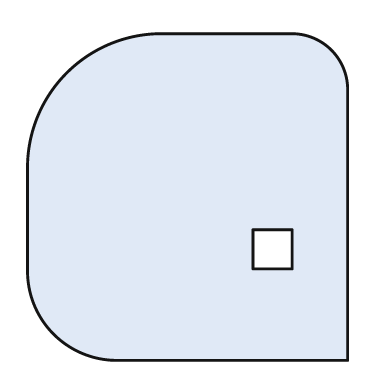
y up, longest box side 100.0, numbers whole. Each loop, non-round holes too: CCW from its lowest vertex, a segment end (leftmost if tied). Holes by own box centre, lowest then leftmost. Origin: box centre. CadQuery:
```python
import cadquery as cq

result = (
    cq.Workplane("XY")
    .moveTo(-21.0, -50.0)
    .lineTo(49.0, -50.0)
    .lineTo(49.0, 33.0)
    .threePointArc((44.0, 45.0), (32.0, 50.0))
    .lineTo(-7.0, 50.0)
    .threePointArc((-37.0, 38.0), (-49.0, 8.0))
    .lineTo(-49.0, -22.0)
    .threePointArc((-41.0, -42.0), (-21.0, -50.0))
    .close()
    .moveTo(20.0, -22.0)
    .lineTo(32.0, -22.0)
    .lineTo(32.0, -10.0)
    .lineTo(20.0, -10.0)
    .close()
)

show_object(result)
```